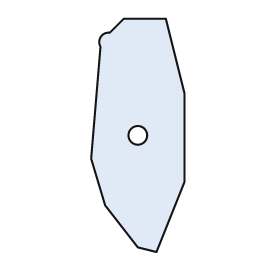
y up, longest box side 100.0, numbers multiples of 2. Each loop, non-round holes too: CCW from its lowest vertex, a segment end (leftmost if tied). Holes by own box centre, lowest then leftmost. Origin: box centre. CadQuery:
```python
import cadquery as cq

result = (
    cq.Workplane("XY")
    .moveTo(8.0, -50.0)
    .lineTo(20.0, -20.0)
    .lineTo(20.0, 18.0)
    .lineTo(12.0, 50.0)
    .lineTo(-6.0, 50.0)
    .lineTo(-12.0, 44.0)
    .threePointArc((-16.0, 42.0), (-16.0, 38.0))
    .lineTo(-20.0, -10.0)
    .lineTo(-14.0, -30.0)
    .lineTo(0.0, -48.0)
    .close()
    .moveTo(0.0, 0.0)
    .circle(4.0)
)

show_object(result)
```